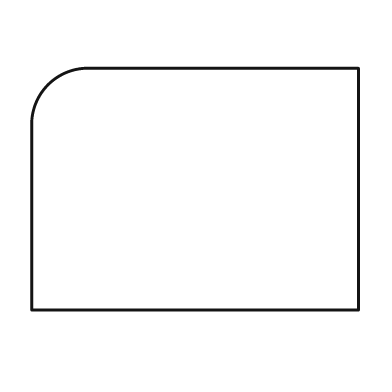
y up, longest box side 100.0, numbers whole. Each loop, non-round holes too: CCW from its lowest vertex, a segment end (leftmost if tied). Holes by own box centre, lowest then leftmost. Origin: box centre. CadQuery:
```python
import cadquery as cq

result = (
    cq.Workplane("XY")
    .moveTo(-50.0, -37.0)
    .lineTo(50.0, -37.0)
    .lineTo(50.0, 37.0)
    .lineTo(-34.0, 37.0)
    .threePointArc((-45.0, 32.0), (-50.0, 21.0))
    .close()
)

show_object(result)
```